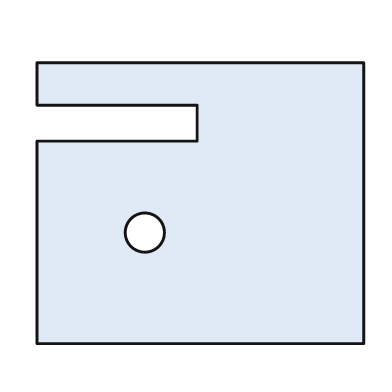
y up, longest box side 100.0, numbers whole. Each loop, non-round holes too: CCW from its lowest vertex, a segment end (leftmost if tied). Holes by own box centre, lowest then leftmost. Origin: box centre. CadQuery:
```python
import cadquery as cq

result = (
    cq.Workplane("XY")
    .moveTo(-50.0, -43.0)
    .lineTo(50.0, -43.0)
    .lineTo(50.0, 43.0)
    .lineTo(-50.0, 43.0)
    .lineTo(-50.0, 30.0)
    .lineTo(-1.0, 30.0)
    .lineTo(-1.0, 19.0)
    .lineTo(-50.0, 19.0)
    .close()
    .moveTo(-17.0, -9.0)
    .circle(6.0)
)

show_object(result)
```